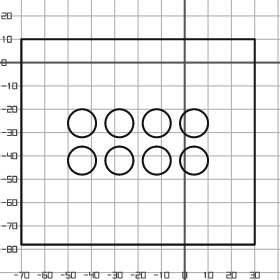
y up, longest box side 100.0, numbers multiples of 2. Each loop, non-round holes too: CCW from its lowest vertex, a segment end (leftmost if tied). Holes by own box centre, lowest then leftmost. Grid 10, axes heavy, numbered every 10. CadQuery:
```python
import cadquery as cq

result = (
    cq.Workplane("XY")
    .moveTo(-70.0, -78.0)
    .lineTo(30.0, -78.0)
    .lineTo(30.0, 10.0)
    .lineTo(-70.0, 10.0)
    .close()
    .moveTo(-44.0, -42.0)
    .circle(6.0)
    .moveTo(-28.0, -42.0)
    .circle(6.0)
    .moveTo(-12.0, -42.0)
    .circle(6.0)
    .moveTo(4.0, -42.0)
    .circle(6.0)
    .moveTo(-44.0, -26.0)
    .circle(6.0)
    .moveTo(-28.0, -26.0)
    .circle(6.0)
    .moveTo(-12.0, -26.0)
    .circle(6.0)
    .moveTo(4.0, -26.0)
    .circle(6.0)
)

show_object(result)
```